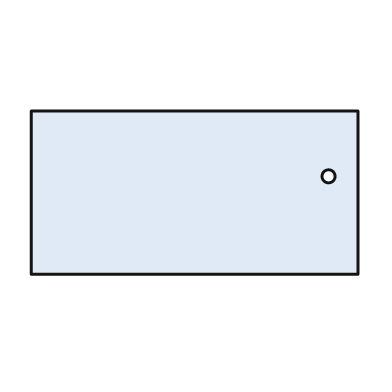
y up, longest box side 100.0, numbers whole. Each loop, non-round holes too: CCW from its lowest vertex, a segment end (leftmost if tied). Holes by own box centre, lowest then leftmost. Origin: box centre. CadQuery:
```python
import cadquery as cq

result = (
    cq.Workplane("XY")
    .moveTo(-50.0, -25.0)
    .lineTo(50.0, -25.0)
    .lineTo(50.0, 25.0)
    .lineTo(-50.0, 25.0)
    .close()
    .moveTo(41.0, 5.0)
    .circle(2.0)
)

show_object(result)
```